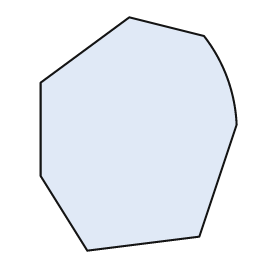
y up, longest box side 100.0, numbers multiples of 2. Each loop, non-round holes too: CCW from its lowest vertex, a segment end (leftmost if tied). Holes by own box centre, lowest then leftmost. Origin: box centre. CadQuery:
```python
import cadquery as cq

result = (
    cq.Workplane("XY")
    .moveTo(-22.0, -50.0)
    .lineTo(26.0, -44.0)
    .lineTo(42.0, 4.0)
    .threePointArc((38.0, 24.0), (28.0, 42.0))
    .lineTo(-4.0, 50.0)
    .lineTo(-42.0, 22.0)
    .lineTo(-42.0, -18.0)
    .close()
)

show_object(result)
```